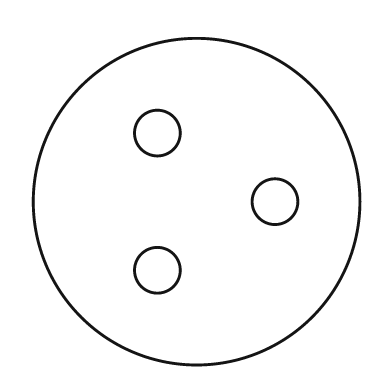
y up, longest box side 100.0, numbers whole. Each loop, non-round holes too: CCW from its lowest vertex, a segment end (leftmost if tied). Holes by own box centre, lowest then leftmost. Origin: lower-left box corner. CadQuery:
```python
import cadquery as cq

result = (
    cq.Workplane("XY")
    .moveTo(50.0, 50.0)
    .circle(50.0)
    .moveTo(38.0, 29.0)
    .circle(7.0)
    .moveTo(74.0, 50.0)
    .circle(7.0)
    .moveTo(38.0, 71.0)
    .circle(7.0)
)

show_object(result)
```